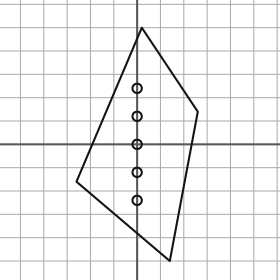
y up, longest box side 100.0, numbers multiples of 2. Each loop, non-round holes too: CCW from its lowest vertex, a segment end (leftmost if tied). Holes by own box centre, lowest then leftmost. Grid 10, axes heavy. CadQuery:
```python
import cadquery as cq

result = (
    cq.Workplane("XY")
    .moveTo(14.0, -50.0)
    .lineTo(26.0, 14.0)
    .lineTo(2.0, 50.0)
    .lineTo(-26.0, -16.0)
    .close()
    .moveTo(0.0, -24.0)
    .circle(2.0)
    .moveTo(0.0, -12.0)
    .circle(2.0)
    .moveTo(0.0, 0.0)
    .circle(2.0)
    .moveTo(0.0, 12.0)
    .circle(2.0)
    .moveTo(0.0, 24.0)
    .circle(2.0)
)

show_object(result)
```